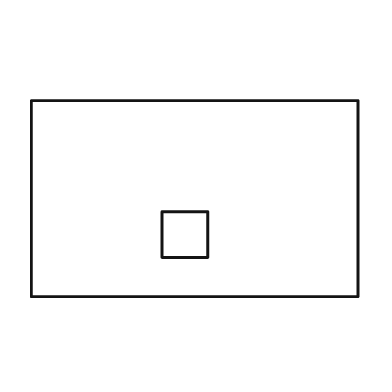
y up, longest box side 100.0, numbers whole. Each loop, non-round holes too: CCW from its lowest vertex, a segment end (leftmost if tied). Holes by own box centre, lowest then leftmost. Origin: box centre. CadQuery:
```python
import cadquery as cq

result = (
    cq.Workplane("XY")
    .moveTo(-50.0, -30.0)
    .lineTo(50.0, -30.0)
    .lineTo(50.0, 30.0)
    .lineTo(-50.0, 30.0)
    .close()
    .moveTo(-10.0, -18.0)
    .lineTo(4.0, -18.0)
    .lineTo(4.0, -4.0)
    .lineTo(-10.0, -4.0)
    .close()
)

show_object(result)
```